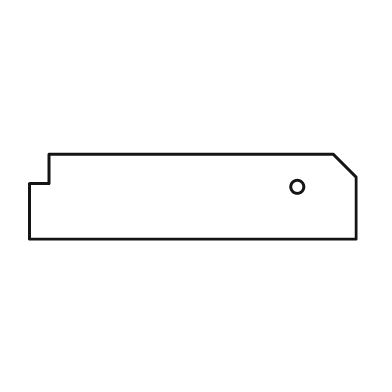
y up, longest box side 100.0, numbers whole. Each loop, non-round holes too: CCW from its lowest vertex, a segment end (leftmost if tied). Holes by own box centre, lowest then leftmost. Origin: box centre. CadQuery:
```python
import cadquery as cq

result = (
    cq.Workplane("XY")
    .moveTo(-50.0, -13.0)
    .lineTo(50.0, -13.0)
    .lineTo(50.0, 6.0)
    .lineTo(43.0, 13.0)
    .lineTo(-44.0, 13.0)
    .lineTo(-44.0, 4.0)
    .lineTo(-50.0, 4.0)
    .close()
    .moveTo(32.0, 3.0)
    .circle(2.0)
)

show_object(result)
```